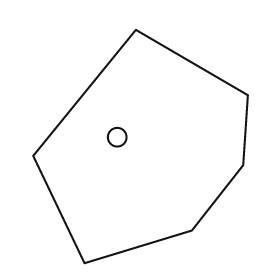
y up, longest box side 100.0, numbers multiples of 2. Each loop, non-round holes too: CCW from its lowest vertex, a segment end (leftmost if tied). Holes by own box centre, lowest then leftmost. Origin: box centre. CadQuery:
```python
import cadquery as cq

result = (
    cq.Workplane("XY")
    .moveTo(-24.0, -50.0)
    .lineTo(22.0, -36.0)
    .lineTo(44.0, -8.0)
    .lineTo(46.0, 22.0)
    .lineTo(-2.0, 50.0)
    .lineTo(-46.0, -4.0)
    .close()
    .moveTo(-10.0, 4.0)
    .circle(4.0)
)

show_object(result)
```